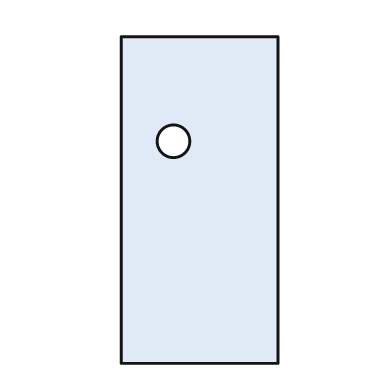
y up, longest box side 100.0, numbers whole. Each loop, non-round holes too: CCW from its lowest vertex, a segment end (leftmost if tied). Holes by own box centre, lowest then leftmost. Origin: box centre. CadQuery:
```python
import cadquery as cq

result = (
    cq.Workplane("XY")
    .moveTo(-24.0, -50.0)
    .lineTo(24.0, -50.0)
    .lineTo(24.0, 50.0)
    .lineTo(-24.0, 50.0)
    .close()
    .moveTo(-8.0, 18.0)
    .circle(5.0)
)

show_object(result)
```